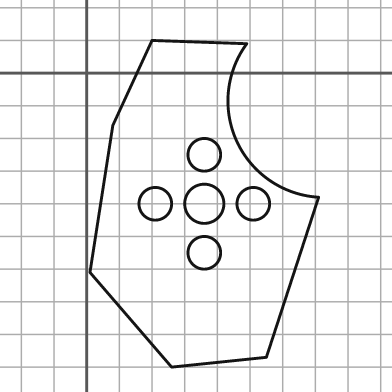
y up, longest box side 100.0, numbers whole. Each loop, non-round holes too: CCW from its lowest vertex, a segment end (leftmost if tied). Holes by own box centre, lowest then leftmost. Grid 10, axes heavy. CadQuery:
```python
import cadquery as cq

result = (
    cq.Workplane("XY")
    .moveTo(26.0, -90.0)
    .lineTo(55.0, -87.0)
    .lineTo(71.0, -38.0)
    .threePointArc((46.0, -21.0), (49.0, 9.0))
    .lineTo(20.0, 10.0)
    .lineTo(8.0, -16.0)
    .lineTo(1.0, -61.0)
    .close()
    .moveTo(36.0, -55.0)
    .circle(5.0)
    .moveTo(21.0, -40.0)
    .circle(5.0)
    .moveTo(36.0, -40.0)
    .circle(6.0)
    .moveTo(51.0, -40.0)
    .circle(5.0)
    .moveTo(36.0, -25.0)
    .circle(5.0)
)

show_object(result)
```